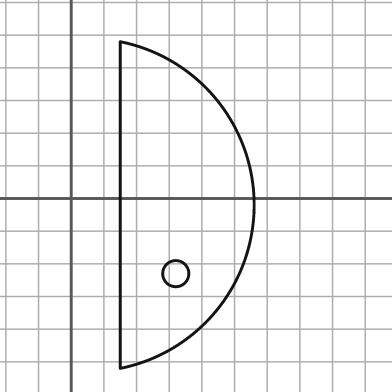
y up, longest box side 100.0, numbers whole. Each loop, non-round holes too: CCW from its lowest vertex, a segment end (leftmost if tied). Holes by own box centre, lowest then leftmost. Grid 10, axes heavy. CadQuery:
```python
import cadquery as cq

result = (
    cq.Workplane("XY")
    .moveTo(15.0, -52.0)
    .threePointArc((56.0, -2.0), (15.0, 48.0))
    .close()
    .moveTo(32.0, -23.0)
    .circle(4.0)
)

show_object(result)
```